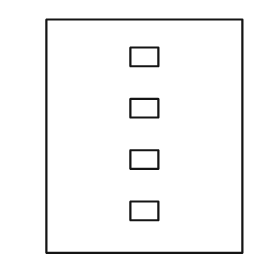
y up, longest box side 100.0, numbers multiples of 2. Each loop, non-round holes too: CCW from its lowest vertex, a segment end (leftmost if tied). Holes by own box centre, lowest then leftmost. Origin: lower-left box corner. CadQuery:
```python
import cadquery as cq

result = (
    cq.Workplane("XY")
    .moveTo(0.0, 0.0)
    .lineTo(84.0, 0.0)
    .lineTo(84.0, 100.0)
    .lineTo(0.0, 100.0)
    .close()
    .moveTo(36.0, 14.0)
    .lineTo(48.0, 14.0)
    .lineTo(48.0, 22.0)
    .lineTo(36.0, 22.0)
    .close()
    .moveTo(36.0, 36.0)
    .lineTo(48.0, 36.0)
    .lineTo(48.0, 44.0)
    .lineTo(36.0, 44.0)
    .close()
    .moveTo(36.0, 58.0)
    .lineTo(48.0, 58.0)
    .lineTo(48.0, 66.0)
    .lineTo(36.0, 66.0)
    .close()
    .moveTo(36.0, 80.0)
    .lineTo(48.0, 80.0)
    .lineTo(48.0, 88.0)
    .lineTo(36.0, 88.0)
    .close()
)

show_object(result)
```